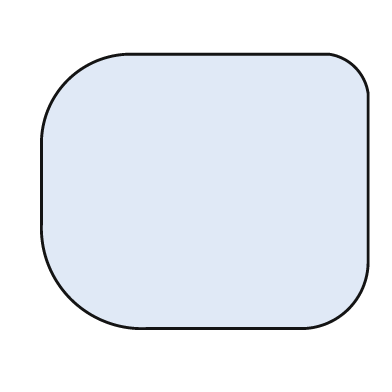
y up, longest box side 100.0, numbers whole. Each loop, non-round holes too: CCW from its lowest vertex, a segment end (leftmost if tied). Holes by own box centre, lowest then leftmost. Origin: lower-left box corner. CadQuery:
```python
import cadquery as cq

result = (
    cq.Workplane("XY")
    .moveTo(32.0, 0.0)
    .lineTo(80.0, 0.0)
    .threePointArc((94.0, 6.0), (100.0, 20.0))
    .lineTo(100.0, 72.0)
    .threePointArc((96.0, 80.0), (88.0, 84.0))
    .lineTo(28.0, 84.0)
    .threePointArc((8.0, 76.0), (0.0, 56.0))
    .lineTo(0.0, 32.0)
    .threePointArc((9.0, 9.0), (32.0, 0.0))
    .close()
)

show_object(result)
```